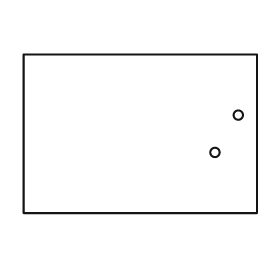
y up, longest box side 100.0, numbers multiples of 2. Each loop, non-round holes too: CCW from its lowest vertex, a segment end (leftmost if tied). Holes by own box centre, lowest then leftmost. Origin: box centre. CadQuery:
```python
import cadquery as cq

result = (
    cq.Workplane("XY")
    .moveTo(-50.0, -34.0)
    .lineTo(50.0, -34.0)
    .lineTo(50.0, 34.0)
    .lineTo(-50.0, 34.0)
    .close()
    .moveTo(32.0, -8.0)
    .circle(2.0)
    .moveTo(42.0, 8.0)
    .circle(2.0)
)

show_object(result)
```